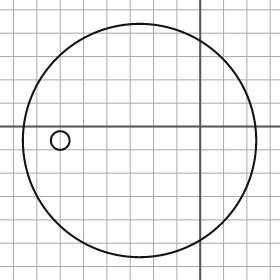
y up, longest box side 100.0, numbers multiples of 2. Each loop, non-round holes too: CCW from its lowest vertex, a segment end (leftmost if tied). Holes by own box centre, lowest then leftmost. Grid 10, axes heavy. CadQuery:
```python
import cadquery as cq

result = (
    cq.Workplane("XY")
    .moveTo(-26.0, -6.0)
    .circle(50.0)
    .moveTo(-60.0, -6.0)
    .circle(4.0)
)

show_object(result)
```